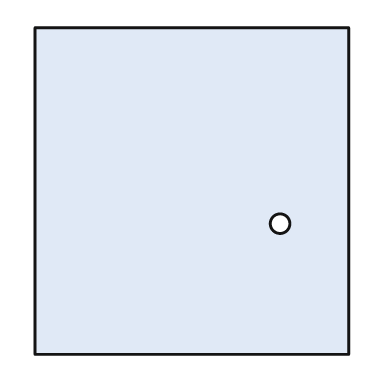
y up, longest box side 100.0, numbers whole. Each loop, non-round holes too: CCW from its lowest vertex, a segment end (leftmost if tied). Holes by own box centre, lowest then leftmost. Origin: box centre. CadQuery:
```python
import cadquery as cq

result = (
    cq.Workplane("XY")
    .moveTo(-48.0, -50.0)
    .lineTo(48.0, -50.0)
    .lineTo(48.0, 50.0)
    .lineTo(-48.0, 50.0)
    .close()
    .moveTo(27.0, -10.0)
    .circle(3.0)
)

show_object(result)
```